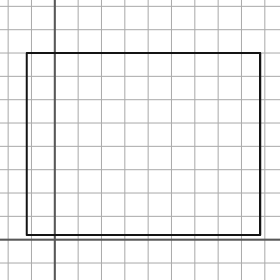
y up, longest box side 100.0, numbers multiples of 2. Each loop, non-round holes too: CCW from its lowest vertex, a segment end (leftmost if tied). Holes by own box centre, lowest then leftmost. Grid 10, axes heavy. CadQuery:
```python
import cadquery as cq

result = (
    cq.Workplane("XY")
    .moveTo(-12.0, 2.0)
    .lineTo(88.0, 2.0)
    .lineTo(88.0, 80.0)
    .lineTo(-12.0, 80.0)
    .close()
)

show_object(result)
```